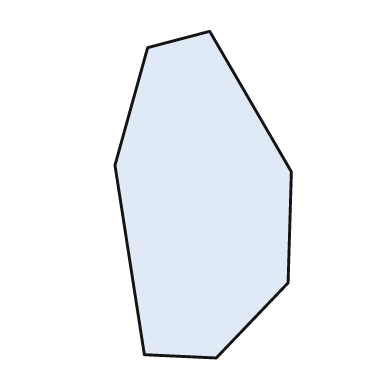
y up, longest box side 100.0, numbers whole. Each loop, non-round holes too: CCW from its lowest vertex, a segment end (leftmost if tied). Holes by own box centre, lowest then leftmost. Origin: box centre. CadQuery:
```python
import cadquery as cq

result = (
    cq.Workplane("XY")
    .moveTo(4.0, -50.0)
    .lineTo(26.0, -27.0)
    .lineTo(27.0, 7.0)
    .lineTo(2.0, 50.0)
    .lineTo(-17.0, 45.0)
    .lineTo(-27.0, 9.0)
    .lineTo(-18.0, -49.0)
    .close()
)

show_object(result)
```